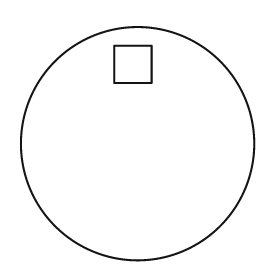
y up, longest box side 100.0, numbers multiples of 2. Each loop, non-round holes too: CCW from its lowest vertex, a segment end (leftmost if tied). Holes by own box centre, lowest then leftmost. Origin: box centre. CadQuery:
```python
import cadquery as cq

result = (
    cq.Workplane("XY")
    .moveTo(0.0, 0.0)
    .circle(50.0)
    .moveTo(-10.0, 26.0)
    .lineTo(6.0, 26.0)
    .lineTo(6.0, 42.0)
    .lineTo(-10.0, 42.0)
    .close()
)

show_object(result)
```